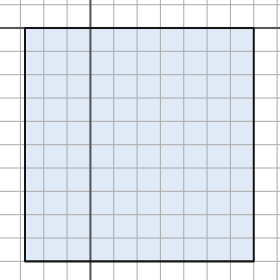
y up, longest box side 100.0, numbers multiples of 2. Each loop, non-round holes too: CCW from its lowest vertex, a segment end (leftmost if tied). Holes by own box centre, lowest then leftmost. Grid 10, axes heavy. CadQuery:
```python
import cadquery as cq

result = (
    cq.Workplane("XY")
    .moveTo(-28.0, -100.0)
    .lineTo(70.0, -100.0)
    .lineTo(70.0, 0.0)
    .lineTo(-28.0, 0.0)
    .close()
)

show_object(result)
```